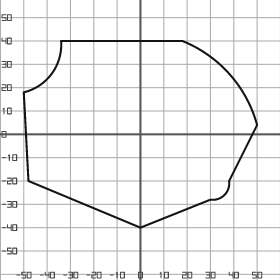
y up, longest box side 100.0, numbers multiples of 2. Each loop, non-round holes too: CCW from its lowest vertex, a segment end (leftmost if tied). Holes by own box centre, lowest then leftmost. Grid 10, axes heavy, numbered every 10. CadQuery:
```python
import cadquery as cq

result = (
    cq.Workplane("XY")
    .moveTo(0.0, -40.0)
    .lineTo(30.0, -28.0)
    .threePointArc((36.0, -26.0), (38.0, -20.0))
    .lineTo(50.0, 4.0)
    .threePointArc((38.0, 26.0), (18.0, 40.0))
    .lineTo(-34.0, 40.0)
    .threePointArc((-38.0, 26.0), (-50.0, 18.0))
    .lineTo(-48.0, -20.0)
    .close()
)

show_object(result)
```